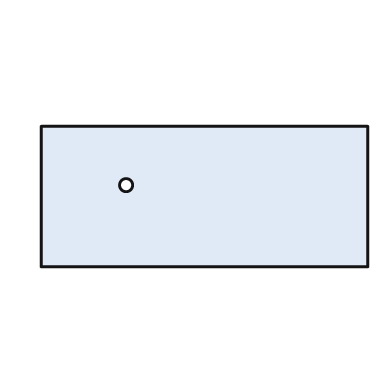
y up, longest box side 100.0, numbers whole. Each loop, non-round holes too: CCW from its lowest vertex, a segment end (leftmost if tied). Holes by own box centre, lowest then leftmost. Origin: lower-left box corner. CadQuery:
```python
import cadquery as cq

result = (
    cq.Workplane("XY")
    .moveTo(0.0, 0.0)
    .lineTo(100.0, 0.0)
    .lineTo(100.0, 43.0)
    .lineTo(0.0, 43.0)
    .close()
    .moveTo(26.0, 25.0)
    .circle(2.0)
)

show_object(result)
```